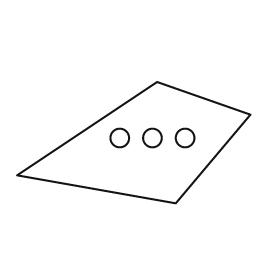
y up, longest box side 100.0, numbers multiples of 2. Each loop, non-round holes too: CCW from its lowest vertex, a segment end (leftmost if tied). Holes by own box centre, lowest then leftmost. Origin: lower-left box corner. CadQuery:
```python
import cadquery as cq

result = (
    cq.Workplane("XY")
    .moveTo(68.0, 0.0)
    .lineTo(100.0, 38.0)
    .lineTo(60.0, 52.0)
    .lineTo(0.0, 12.0)
    .close()
    .moveTo(44.0, 28.0)
    .circle(4.0)
    .moveTo(58.0, 28.0)
    .circle(4.0)
    .moveTo(72.0, 28.0)
    .circle(4.0)
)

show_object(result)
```